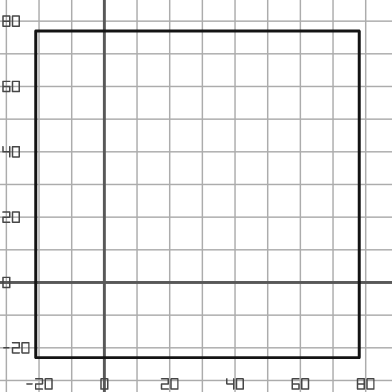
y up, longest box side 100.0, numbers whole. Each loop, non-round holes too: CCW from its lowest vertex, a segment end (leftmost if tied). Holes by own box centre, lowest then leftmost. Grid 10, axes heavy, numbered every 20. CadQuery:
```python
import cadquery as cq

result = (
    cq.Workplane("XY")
    .moveTo(-21.0, -23.0)
    .lineTo(78.0, -23.0)
    .lineTo(78.0, 77.0)
    .lineTo(-21.0, 77.0)
    .close()
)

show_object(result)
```